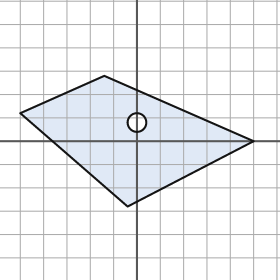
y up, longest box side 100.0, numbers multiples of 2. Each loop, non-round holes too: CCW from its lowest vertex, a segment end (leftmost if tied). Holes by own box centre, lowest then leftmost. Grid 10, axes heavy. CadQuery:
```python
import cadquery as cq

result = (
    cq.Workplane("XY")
    .moveTo(-4.0, -28.0)
    .lineTo(50.0, 0.0)
    .lineTo(-14.0, 28.0)
    .lineTo(-50.0, 12.0)
    .close()
    .moveTo(0.0, 8.0)
    .circle(4.0)
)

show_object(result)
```